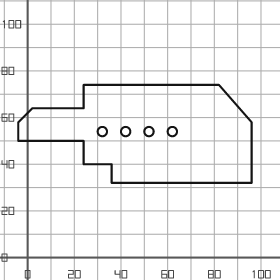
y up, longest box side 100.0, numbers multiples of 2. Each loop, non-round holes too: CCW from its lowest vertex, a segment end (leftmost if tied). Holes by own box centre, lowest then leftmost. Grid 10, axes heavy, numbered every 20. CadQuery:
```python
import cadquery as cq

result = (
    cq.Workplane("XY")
    .moveTo(36.0, 32.0)
    .lineTo(96.0, 32.0)
    .lineTo(96.0, 58.0)
    .lineTo(82.0, 74.0)
    .lineTo(24.0, 74.0)
    .lineTo(24.0, 64.0)
    .lineTo(2.0, 64.0)
    .lineTo(-4.0, 58.0)
    .lineTo(-4.0, 50.0)
    .lineTo(24.0, 50.0)
    .lineTo(24.0, 40.0)
    .lineTo(36.0, 40.0)
    .close()
    .moveTo(32.0, 54.0)
    .circle(2.0)
    .moveTo(42.0, 54.0)
    .circle(2.0)
    .moveTo(52.0, 54.0)
    .circle(2.0)
    .moveTo(62.0, 54.0)
    .circle(2.0)
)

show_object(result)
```